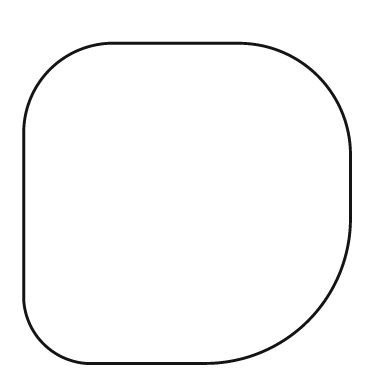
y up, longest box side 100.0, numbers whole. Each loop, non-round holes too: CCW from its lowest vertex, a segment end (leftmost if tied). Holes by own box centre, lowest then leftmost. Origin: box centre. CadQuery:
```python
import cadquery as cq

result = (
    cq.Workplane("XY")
    .moveTo(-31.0, -49.0)
    .lineTo(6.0, -49.0)
    .threePointArc((37.0, -36.0), (50.0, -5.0))
    .lineTo(50.0, 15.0)
    .threePointArc((40.0, 39.0), (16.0, 49.0))
    .lineTo(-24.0, 49.0)
    .threePointArc((-42.0, 41.0), (-50.0, 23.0))
    .lineTo(-50.0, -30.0)
    .threePointArc((-44.0, -43.0), (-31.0, -49.0))
    .close()
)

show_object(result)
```